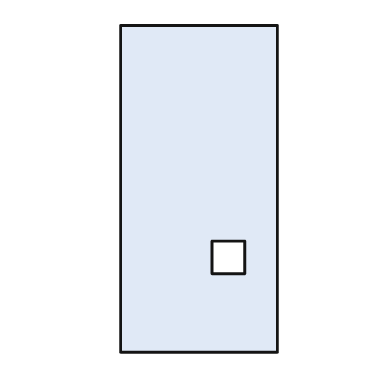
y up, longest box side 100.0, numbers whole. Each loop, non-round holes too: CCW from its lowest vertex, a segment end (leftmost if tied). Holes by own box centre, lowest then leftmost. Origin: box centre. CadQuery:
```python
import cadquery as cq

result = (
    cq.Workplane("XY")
    .moveTo(-24.0, -50.0)
    .lineTo(24.0, -50.0)
    .lineTo(24.0, 50.0)
    .lineTo(-24.0, 50.0)
    .close()
    .moveTo(4.0, -26.0)
    .lineTo(14.0, -26.0)
    .lineTo(14.0, -16.0)
    .lineTo(4.0, -16.0)
    .close()
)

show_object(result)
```